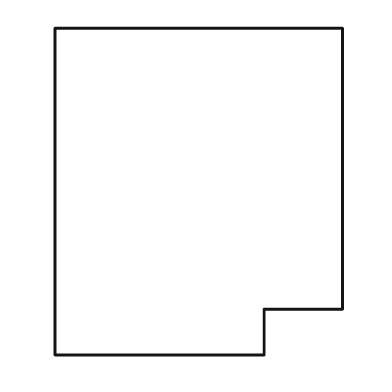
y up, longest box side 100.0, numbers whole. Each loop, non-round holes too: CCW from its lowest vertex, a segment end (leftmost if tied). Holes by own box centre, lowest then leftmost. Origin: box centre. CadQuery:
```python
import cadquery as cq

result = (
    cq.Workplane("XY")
    .moveTo(-44.0, -50.0)
    .lineTo(20.0, -50.0)
    .lineTo(20.0, -36.0)
    .lineTo(44.0, -36.0)
    .lineTo(44.0, 50.0)
    .lineTo(-44.0, 50.0)
    .close()
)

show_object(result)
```